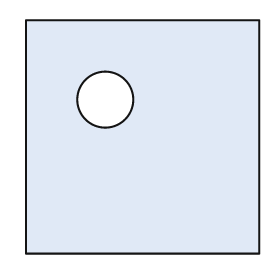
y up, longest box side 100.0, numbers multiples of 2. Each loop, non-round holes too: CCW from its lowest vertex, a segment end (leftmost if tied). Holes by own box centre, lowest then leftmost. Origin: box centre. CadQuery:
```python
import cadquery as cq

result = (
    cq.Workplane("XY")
    .moveTo(-50.0, -50.0)
    .lineTo(50.0, -50.0)
    .lineTo(50.0, 50.0)
    .lineTo(-50.0, 50.0)
    .close()
    .moveTo(-16.0, 16.0)
    .circle(12.0)
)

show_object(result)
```